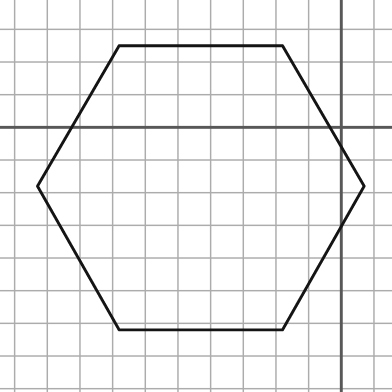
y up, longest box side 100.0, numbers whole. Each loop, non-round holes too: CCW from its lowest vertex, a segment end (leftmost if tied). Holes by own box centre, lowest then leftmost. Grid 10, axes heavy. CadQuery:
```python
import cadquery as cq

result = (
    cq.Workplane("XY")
    .moveTo(-68.0, -62.0)
    .lineTo(-18.0, -62.0)
    .lineTo(7.0, -18.0)
    .lineTo(-18.0, 25.0)
    .lineTo(-68.0, 25.0)
    .lineTo(-93.0, -18.0)
    .close()
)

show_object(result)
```